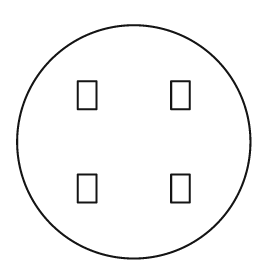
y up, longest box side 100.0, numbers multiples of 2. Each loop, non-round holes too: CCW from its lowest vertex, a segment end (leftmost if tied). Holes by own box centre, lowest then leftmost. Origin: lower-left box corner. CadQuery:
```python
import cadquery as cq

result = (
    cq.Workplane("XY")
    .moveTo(50.0, 50.0)
    .circle(50.0)
    .moveTo(26.0, 24.0)
    .lineTo(34.0, 24.0)
    .lineTo(34.0, 36.0)
    .lineTo(26.0, 36.0)
    .close()
    .moveTo(66.0, 24.0)
    .lineTo(74.0, 24.0)
    .lineTo(74.0, 36.0)
    .lineTo(66.0, 36.0)
    .close()
    .moveTo(26.0, 64.0)
    .lineTo(34.0, 64.0)
    .lineTo(34.0, 76.0)
    .lineTo(26.0, 76.0)
    .close()
    .moveTo(66.0, 64.0)
    .lineTo(74.0, 64.0)
    .lineTo(74.0, 76.0)
    .lineTo(66.0, 76.0)
    .close()
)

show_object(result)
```